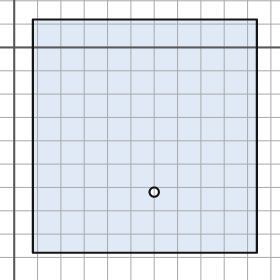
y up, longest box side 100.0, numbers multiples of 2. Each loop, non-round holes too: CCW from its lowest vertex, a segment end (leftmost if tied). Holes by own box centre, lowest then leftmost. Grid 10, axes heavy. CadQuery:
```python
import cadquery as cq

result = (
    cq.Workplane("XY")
    .moveTo(8.0, -88.0)
    .lineTo(104.0, -88.0)
    .lineTo(104.0, 12.0)
    .lineTo(8.0, 12.0)
    .close()
    .moveTo(60.0, -62.0)
    .circle(2.0)
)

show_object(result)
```